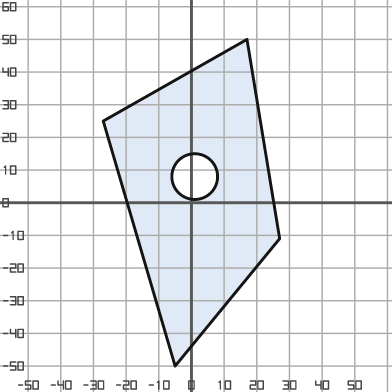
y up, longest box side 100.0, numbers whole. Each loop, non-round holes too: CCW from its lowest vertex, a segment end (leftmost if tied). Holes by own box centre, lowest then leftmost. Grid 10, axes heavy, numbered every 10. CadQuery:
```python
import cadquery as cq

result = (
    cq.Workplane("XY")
    .moveTo(-5.0, -50.0)
    .lineTo(27.0, -11.0)
    .lineTo(17.0, 50.0)
    .lineTo(-27.0, 25.0)
    .close()
    .moveTo(1.0, 8.0)
    .circle(7.0)
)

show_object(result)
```